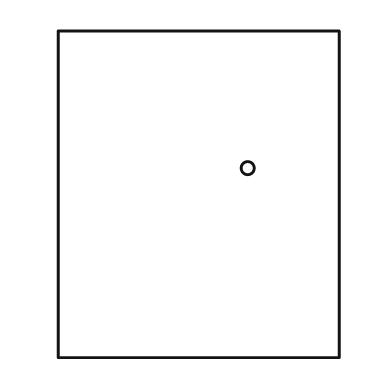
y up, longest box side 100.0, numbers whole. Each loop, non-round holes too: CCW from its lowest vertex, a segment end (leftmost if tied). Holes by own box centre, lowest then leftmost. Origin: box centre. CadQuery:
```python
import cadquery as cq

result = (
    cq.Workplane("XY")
    .moveTo(-43.0, -50.0)
    .lineTo(43.0, -50.0)
    .lineTo(43.0, 50.0)
    .lineTo(-43.0, 50.0)
    .close()
    .moveTo(15.0, 8.0)
    .circle(2.0)
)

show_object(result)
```